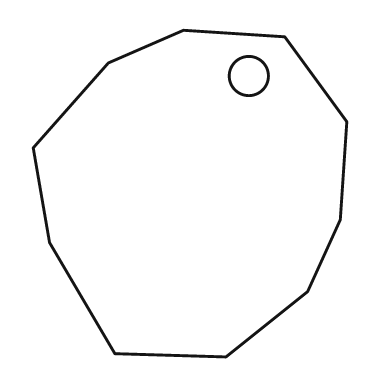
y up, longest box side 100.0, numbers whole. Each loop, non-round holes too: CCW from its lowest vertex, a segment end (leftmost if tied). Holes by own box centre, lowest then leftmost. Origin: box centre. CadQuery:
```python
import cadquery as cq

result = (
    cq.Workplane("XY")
    .moveTo(11.0, -50.0)
    .lineTo(36.0, -30.0)
    .lineTo(46.0, -8.0)
    .lineTo(48.0, 22.0)
    .lineTo(29.0, 48.0)
    .lineTo(-2.0, 50.0)
    .lineTo(-25.0, 40.0)
    .lineTo(-48.0, 14.0)
    .lineTo(-43.0, -15.0)
    .lineTo(-23.0, -49.0)
    .close()
    .moveTo(18.0, 36.0)
    .circle(6.0)
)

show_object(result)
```